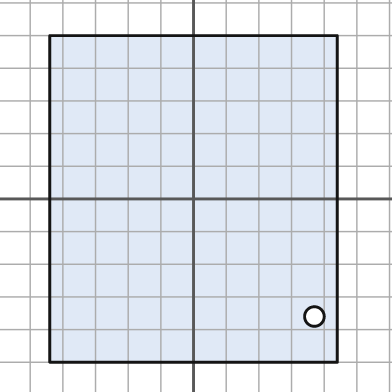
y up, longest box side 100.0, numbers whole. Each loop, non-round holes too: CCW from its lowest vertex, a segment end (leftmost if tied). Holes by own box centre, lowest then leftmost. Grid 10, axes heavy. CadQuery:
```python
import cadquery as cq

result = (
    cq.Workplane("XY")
    .moveTo(-44.0, -50.0)
    .lineTo(44.0, -50.0)
    .lineTo(44.0, 50.0)
    .lineTo(-44.0, 50.0)
    .close()
    .moveTo(37.0, -36.0)
    .circle(3.0)
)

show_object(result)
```